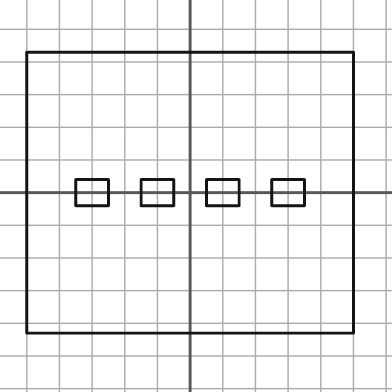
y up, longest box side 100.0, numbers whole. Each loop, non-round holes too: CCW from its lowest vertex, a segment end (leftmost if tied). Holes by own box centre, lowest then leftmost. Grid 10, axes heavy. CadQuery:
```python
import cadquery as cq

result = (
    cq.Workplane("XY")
    .moveTo(-50.0, -43.0)
    .lineTo(50.0, -43.0)
    .lineTo(50.0, 43.0)
    .lineTo(-50.0, 43.0)
    .close()
    .moveTo(-35.0, -4.0)
    .lineTo(-25.0, -4.0)
    .lineTo(-25.0, 4.0)
    .lineTo(-35.0, 4.0)
    .close()
    .moveTo(-15.0, -4.0)
    .lineTo(-5.0, -4.0)
    .lineTo(-5.0, 4.0)
    .lineTo(-15.0, 4.0)
    .close()
    .moveTo(5.0, -4.0)
    .lineTo(15.0, -4.0)
    .lineTo(15.0, 4.0)
    .lineTo(5.0, 4.0)
    .close()
    .moveTo(25.0, -4.0)
    .lineTo(35.0, -4.0)
    .lineTo(35.0, 4.0)
    .lineTo(25.0, 4.0)
    .close()
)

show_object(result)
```